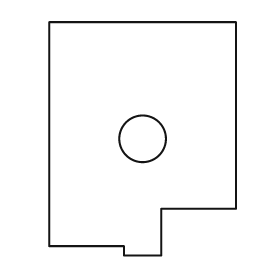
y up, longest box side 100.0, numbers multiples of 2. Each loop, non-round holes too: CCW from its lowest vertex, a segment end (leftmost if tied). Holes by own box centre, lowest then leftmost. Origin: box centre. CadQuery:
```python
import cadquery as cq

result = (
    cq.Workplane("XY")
    .moveTo(-8.0, -50.0)
    .lineTo(8.0, -50.0)
    .lineTo(8.0, -30.0)
    .lineTo(40.0, -30.0)
    .lineTo(40.0, 50.0)
    .lineTo(-40.0, 50.0)
    .lineTo(-40.0, -46.0)
    .lineTo(-8.0, -46.0)
    .close()
    .moveTo(0.0, 0.0)
    .circle(10.0)
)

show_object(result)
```